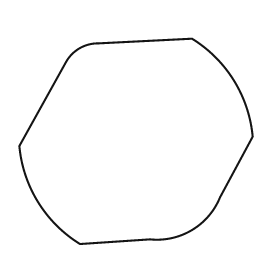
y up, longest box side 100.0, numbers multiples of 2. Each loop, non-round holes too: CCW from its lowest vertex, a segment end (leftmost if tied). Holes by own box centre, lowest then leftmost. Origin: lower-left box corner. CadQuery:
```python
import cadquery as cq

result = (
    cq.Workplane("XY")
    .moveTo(26.0, 0.0)
    .lineTo(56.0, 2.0)
    .threePointArc((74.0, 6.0), (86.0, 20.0))
    .lineTo(100.0, 46.0)
    .threePointArc((92.0, 70.0), (74.0, 88.0))
    .lineTo(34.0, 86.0)
    .threePointArc((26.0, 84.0), (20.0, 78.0))
    .lineTo(0.0, 42.0)
    .threePointArc((8.0, 18.0), (26.0, 0.0))
    .close()
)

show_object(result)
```